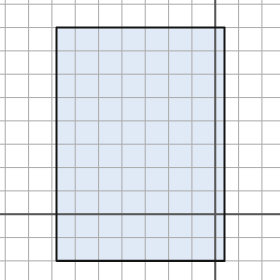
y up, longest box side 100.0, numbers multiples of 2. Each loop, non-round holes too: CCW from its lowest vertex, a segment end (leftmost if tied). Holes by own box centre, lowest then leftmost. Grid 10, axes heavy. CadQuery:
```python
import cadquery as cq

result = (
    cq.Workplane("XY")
    .moveTo(-68.0, -20.0)
    .lineTo(4.0, -20.0)
    .lineTo(4.0, 80.0)
    .lineTo(-68.0, 80.0)
    .close()
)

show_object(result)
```